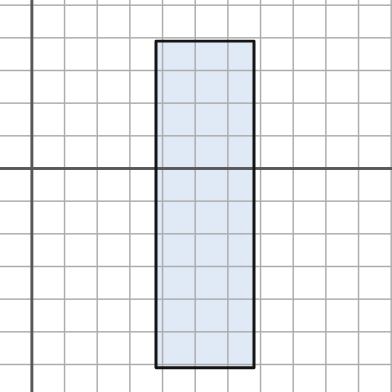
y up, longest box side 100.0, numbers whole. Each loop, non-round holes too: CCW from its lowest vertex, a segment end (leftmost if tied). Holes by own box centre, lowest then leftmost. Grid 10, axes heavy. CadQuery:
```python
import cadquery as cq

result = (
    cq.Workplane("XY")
    .moveTo(38.0, -61.0)
    .lineTo(68.0, -61.0)
    .lineTo(68.0, 39.0)
    .lineTo(38.0, 39.0)
    .close()
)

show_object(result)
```